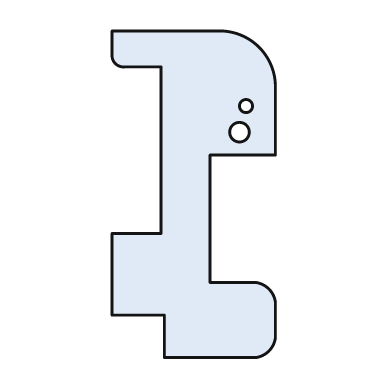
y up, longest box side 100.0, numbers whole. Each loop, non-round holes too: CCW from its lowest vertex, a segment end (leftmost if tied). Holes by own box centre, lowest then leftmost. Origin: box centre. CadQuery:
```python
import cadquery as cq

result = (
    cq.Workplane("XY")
    .moveTo(-9.0, -50.0)
    .lineTo(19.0, -50.0)
    .threePointArc((23.0, -48.0), (25.0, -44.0))
    .lineTo(25.0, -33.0)
    .threePointArc((23.0, -29.0), (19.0, -27.0))
    .lineTo(5.0, -27.0)
    .lineTo(5.0, 12.0)
    .lineTo(25.0, 12.0)
    .lineTo(25.0, 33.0)
    .threePointArc((20.0, 45.0), (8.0, 50.0))
    .lineTo(-25.0, 50.0)
    .lineTo(-25.0, 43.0)
    .threePointArc((-24.0, 40.0), (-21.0, 39.0))
    .lineTo(-10.0, 39.0)
    .lineTo(-10.0, -12.0)
    .lineTo(-25.0, -12.0)
    .lineTo(-25.0, -37.0)
    .lineTo(-9.0, -37.0)
    .close()
    .moveTo(14.0, 19.0)
    .circle(3.0)
    .moveTo(16.0, 27.0)
    .circle(2.0)
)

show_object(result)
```